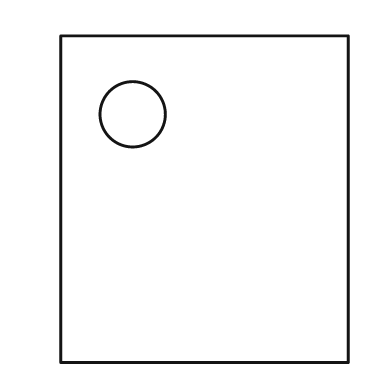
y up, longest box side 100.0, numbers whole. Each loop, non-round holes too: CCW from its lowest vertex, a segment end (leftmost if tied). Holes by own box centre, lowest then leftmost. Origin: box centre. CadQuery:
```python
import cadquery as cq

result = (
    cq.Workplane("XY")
    .moveTo(-44.0, -50.0)
    .lineTo(44.0, -50.0)
    .lineTo(44.0, 50.0)
    .lineTo(-44.0, 50.0)
    .close()
    .moveTo(-22.0, 26.0)
    .circle(10.0)
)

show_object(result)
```